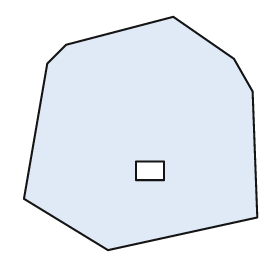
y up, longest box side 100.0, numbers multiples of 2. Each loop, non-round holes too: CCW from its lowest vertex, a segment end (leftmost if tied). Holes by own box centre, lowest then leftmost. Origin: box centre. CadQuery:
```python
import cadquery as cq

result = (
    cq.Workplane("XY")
    .moveTo(-14.0, -50.0)
    .lineTo(50.0, -36.0)
    .lineTo(48.0, 18.0)
    .lineTo(40.0, 32.0)
    .lineTo(14.0, 50.0)
    .lineTo(-32.0, 38.0)
    .lineTo(-40.0, 30.0)
    .lineTo(-50.0, -28.0)
    .close()
    .moveTo(-2.0, -20.0)
    .lineTo(10.0, -20.0)
    .lineTo(10.0, -12.0)
    .lineTo(-2.0, -12.0)
    .close()
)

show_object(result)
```